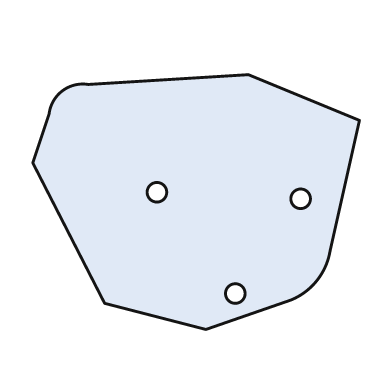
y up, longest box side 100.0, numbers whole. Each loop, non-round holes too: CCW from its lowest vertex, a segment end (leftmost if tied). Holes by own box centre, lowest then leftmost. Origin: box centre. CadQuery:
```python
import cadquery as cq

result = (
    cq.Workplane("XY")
    .moveTo(3.0, -39.0)
    .lineTo(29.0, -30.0)
    .threePointArc((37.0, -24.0), (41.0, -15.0))
    .lineTo(50.0, 25.0)
    .lineTo(16.0, 39.0)
    .lineTo(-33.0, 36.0)
    .threePointArc((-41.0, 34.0), (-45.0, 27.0))
    .lineTo(-50.0, 12.0)
    .lineTo(-28.0, -31.0)
    .close()
    .moveTo(12.0, -28.0)
    .circle(3.0)
    .moveTo(32.0, 1.0)
    .circle(3.0)
    .moveTo(-12.0, 3.0)
    .circle(3.0)
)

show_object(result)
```